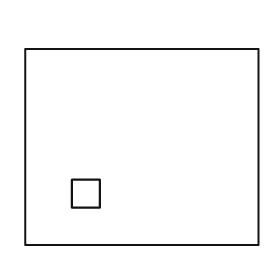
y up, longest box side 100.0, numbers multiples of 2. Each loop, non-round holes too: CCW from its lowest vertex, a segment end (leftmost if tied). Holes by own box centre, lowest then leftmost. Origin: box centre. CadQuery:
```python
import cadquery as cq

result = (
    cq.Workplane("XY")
    .moveTo(-50.0, -42.0)
    .lineTo(50.0, -42.0)
    .lineTo(50.0, 42.0)
    .lineTo(-50.0, 42.0)
    .close()
    .moveTo(-30.0, -26.0)
    .lineTo(-18.0, -26.0)
    .lineTo(-18.0, -14.0)
    .lineTo(-30.0, -14.0)
    .close()
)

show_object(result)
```